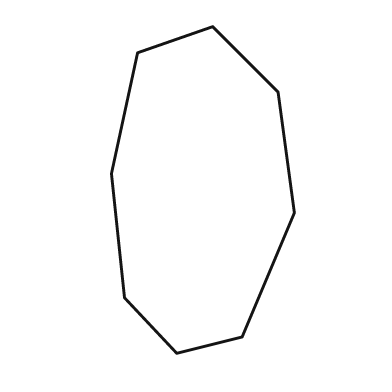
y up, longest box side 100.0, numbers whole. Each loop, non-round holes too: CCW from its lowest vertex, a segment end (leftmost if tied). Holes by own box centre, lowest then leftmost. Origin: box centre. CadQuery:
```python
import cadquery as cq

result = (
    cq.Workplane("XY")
    .moveTo(-8.0, -50.0)
    .lineTo(12.0, -45.0)
    .lineTo(28.0, -7.0)
    .lineTo(23.0, 30.0)
    .lineTo(3.0, 50.0)
    .lineTo(-20.0, 42.0)
    .lineTo(-28.0, 5.0)
    .lineTo(-24.0, -33.0)
    .close()
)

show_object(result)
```